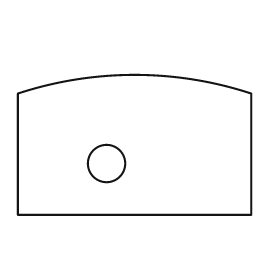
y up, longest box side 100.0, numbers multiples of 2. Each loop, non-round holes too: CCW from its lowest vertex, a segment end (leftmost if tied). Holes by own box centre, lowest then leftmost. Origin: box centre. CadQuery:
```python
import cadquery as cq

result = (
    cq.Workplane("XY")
    .moveTo(-50.0, -30.0)
    .lineTo(50.0, -30.0)
    .lineTo(50.0, 22.0)
    .threePointArc((0.0, 30.0), (-50.0, 22.0))
    .close()
    .moveTo(-12.0, -8.0)
    .circle(8.0)
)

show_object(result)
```